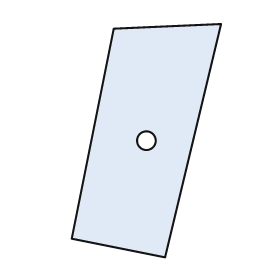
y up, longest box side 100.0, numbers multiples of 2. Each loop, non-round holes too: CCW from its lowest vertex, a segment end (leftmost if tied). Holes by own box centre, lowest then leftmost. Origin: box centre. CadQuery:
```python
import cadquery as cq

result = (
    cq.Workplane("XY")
    .moveTo(8.0, -50.0)
    .lineTo(32.0, 50.0)
    .lineTo(-14.0, 48.0)
    .lineTo(-32.0, -42.0)
    .close()
    .moveTo(0.0, 0.0)
    .circle(4.0)
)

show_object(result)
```